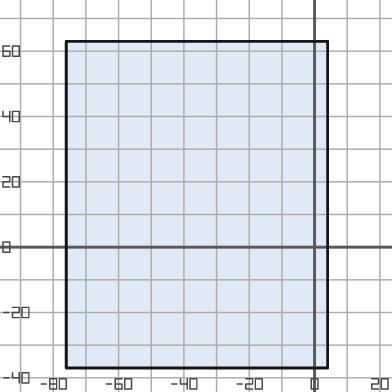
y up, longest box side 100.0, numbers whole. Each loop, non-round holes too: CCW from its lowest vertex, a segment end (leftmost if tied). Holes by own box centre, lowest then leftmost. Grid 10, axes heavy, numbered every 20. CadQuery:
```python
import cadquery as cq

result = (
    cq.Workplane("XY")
    .moveTo(-76.0, -37.0)
    .lineTo(4.0, -37.0)
    .lineTo(4.0, 63.0)
    .lineTo(-76.0, 63.0)
    .close()
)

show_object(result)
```